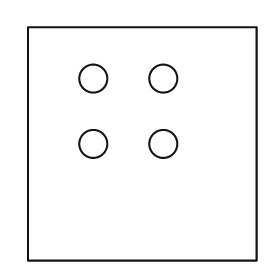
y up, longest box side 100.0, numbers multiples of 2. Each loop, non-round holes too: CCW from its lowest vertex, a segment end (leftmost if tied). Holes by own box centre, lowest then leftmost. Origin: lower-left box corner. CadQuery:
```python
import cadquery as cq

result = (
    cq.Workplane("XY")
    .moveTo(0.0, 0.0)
    .lineTo(98.0, 0.0)
    .lineTo(98.0, 100.0)
    .lineTo(0.0, 100.0)
    .close()
    .moveTo(28.0, 50.0)
    .circle(6.0)
    .moveTo(58.0, 50.0)
    .circle(6.0)
    .moveTo(28.0, 78.0)
    .circle(6.0)
    .moveTo(58.0, 78.0)
    .circle(6.0)
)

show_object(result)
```